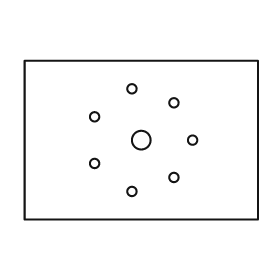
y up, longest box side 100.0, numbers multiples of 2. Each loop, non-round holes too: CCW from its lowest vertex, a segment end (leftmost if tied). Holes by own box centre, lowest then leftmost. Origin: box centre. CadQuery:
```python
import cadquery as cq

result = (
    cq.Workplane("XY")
    .moveTo(-50.0, -34.0)
    .lineTo(50.0, -34.0)
    .lineTo(50.0, 34.0)
    .lineTo(-50.0, 34.0)
    .close()
    .moveTo(-4.0, -22.0)
    .circle(2.0)
    .moveTo(14.0, -16.0)
    .circle(2.0)
    .moveTo(-20.0, -10.0)
    .circle(2.0)
    .moveTo(0.0, 0.0)
    .circle(4.0)
    .moveTo(22.0, 0.0)
    .circle(2.0)
    .moveTo(-20.0, 10.0)
    .circle(2.0)
    .moveTo(14.0, 16.0)
    .circle(2.0)
    .moveTo(-4.0, 22.0)
    .circle(2.0)
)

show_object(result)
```